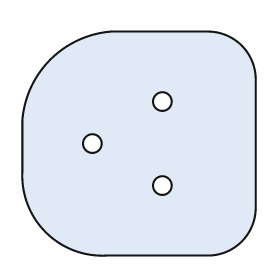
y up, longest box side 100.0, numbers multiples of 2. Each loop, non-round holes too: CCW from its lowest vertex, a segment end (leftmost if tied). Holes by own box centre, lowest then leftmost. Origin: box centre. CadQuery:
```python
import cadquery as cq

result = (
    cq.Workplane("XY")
    .moveTo(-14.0, -48.0)
    .lineTo(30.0, -48.0)
    .threePointArc((44.0, -42.0), (50.0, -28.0))
    .lineTo(50.0, 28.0)
    .threePointArc((44.0, 42.0), (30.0, 48.0))
    .lineTo(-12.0, 48.0)
    .threePointArc((-38.0, 36.0), (-50.0, 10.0))
    .lineTo(-50.0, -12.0)
    .threePointArc((-40.0, -38.0), (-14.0, -48.0))
    .close()
    .moveTo(10.0, -18.0)
    .circle(4.0)
    .moveTo(-20.0, 0.0)
    .circle(4.0)
    .moveTo(10.0, 18.0)
    .circle(4.0)
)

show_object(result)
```